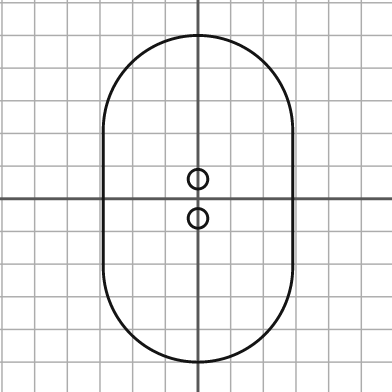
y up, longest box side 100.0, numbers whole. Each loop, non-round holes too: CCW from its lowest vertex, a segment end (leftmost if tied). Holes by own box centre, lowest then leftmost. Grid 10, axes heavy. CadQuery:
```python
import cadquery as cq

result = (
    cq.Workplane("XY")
    .moveTo(-29.0, -21.0)
    .threePointArc((0.0, -50.0), (29.0, -21.0))
    .lineTo(29.0, 21.0)
    .threePointArc((0.0, 50.0), (-29.0, 21.0))
    .close()
    .moveTo(0.0, -6.0)
    .circle(3.0)
    .moveTo(0.0, 6.0)
    .circle(3.0)
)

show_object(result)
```